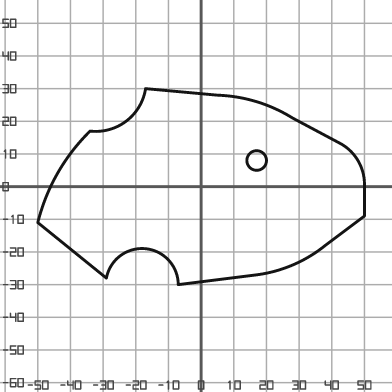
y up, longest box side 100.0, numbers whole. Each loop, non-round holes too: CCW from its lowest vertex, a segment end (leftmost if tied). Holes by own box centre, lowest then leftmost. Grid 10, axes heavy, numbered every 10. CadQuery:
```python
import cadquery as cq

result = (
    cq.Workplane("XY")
    .moveTo(-7.0, -30.0)
    .lineTo(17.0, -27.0)
    .threePointArc((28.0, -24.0), (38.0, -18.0))
    .lineTo(50.0, -9.0)
    .lineTo(50.0, 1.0)
    .threePointArc((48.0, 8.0), (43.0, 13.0))
    .lineTo(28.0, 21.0)
    .threePointArc((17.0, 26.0), (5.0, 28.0))
    .lineTo(-17.0, 30.0)
    .threePointArc((-23.0, 20.0), (-34.0, 17.0))
    .threePointArc((-44.0, 4.0), (-50.0, -11.0))
    .lineTo(-29.0, -28.0)
    .threePointArc((-17.0, -19.0), (-7.0, -30.0))
    .close()
    .moveTo(17.0, 8.0)
    .circle(3.0)
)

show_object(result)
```